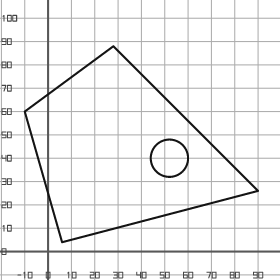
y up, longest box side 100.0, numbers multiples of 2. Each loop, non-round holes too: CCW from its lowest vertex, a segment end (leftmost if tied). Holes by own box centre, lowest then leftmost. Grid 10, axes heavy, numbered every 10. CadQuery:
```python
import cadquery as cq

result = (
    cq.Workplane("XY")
    .moveTo(6.0, 4.0)
    .lineTo(90.0, 26.0)
    .lineTo(28.0, 88.0)
    .lineTo(-10.0, 60.0)
    .close()
    .moveTo(52.0, 40.0)
    .circle(8.0)
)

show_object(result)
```